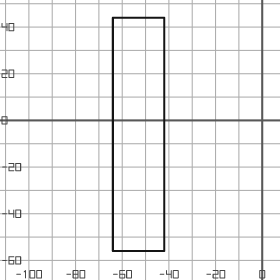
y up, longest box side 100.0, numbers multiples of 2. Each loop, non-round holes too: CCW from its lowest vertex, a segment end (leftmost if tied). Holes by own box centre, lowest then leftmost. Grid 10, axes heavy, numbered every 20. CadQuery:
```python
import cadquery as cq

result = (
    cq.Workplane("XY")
    .moveTo(-64.0, -56.0)
    .lineTo(-42.0, -56.0)
    .lineTo(-42.0, 44.0)
    .lineTo(-64.0, 44.0)
    .close()
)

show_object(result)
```